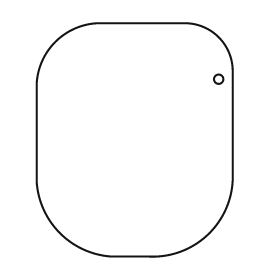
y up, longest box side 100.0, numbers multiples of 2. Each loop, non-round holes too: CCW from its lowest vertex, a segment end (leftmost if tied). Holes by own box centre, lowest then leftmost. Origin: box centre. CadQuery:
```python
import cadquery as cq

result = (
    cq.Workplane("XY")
    .moveTo(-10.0, -50.0)
    .lineTo(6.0, -50.0)
    .threePointArc((32.0, -40.0), (42.0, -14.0))
    .lineTo(42.0, 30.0)
    .threePointArc((36.0, 44.0), (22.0, 50.0))
    .lineTo(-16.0, 50.0)
    .threePointArc((-34.0, 42.0), (-42.0, 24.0))
    .lineTo(-42.0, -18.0)
    .threePointArc((-32.0, -40.0), (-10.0, -50.0))
    .close()
    .moveTo(36.0, 26.0)
    .circle(2.0)
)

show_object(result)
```